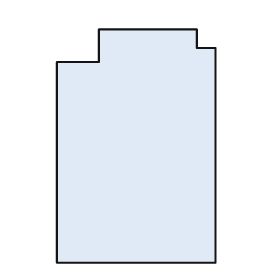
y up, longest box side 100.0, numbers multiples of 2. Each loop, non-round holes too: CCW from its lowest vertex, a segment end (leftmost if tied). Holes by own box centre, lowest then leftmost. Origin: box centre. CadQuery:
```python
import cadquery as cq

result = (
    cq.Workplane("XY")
    .moveTo(-34.0, -50.0)
    .lineTo(34.0, -50.0)
    .lineTo(34.0, 42.0)
    .lineTo(26.0, 42.0)
    .lineTo(26.0, 50.0)
    .lineTo(-16.0, 50.0)
    .lineTo(-16.0, 36.0)
    .lineTo(-34.0, 36.0)
    .close()
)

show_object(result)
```